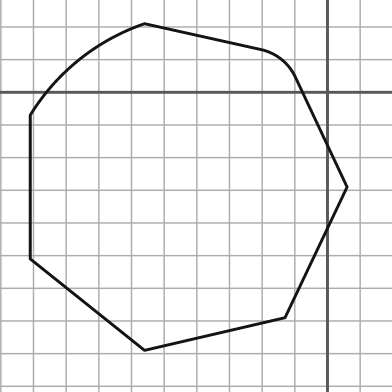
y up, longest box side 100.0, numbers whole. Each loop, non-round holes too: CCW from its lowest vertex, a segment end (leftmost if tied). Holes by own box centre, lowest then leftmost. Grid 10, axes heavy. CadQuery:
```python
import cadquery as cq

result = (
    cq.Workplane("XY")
    .moveTo(-56.0, -79.0)
    .lineTo(-13.0, -69.0)
    .lineTo(6.0, -29.0)
    .lineTo(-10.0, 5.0)
    .threePointArc((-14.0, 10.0), (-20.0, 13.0))
    .lineTo(-56.0, 21.0)
    .threePointArc((-76.0, 10.0), (-91.0, -7.0))
    .lineTo(-91.0, -51.0)
    .close()
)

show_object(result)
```